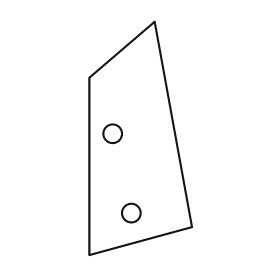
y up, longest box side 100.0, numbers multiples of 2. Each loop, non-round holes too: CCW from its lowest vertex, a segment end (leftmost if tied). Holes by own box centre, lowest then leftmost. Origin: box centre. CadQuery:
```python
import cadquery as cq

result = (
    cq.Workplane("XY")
    .moveTo(-22.0, -50.0)
    .lineTo(22.0, -38.0)
    .lineTo(6.0, 50.0)
    .lineTo(-22.0, 26.0)
    .close()
    .moveTo(-4.0, -32.0)
    .circle(4.0)
    .moveTo(-12.0, 2.0)
    .circle(4.0)
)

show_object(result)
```